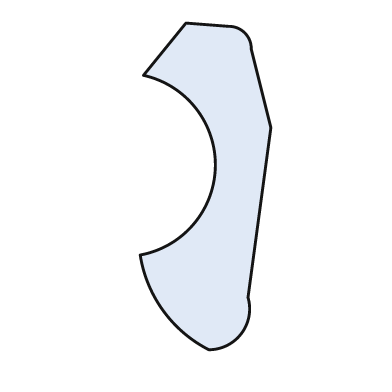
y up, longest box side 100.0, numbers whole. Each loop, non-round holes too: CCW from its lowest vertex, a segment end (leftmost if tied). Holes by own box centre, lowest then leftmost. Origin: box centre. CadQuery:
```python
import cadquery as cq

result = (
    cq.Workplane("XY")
    .moveTo(1.0, -50.0)
    .threePointArc((11.0, -45.0), (13.0, -34.0))
    .lineTo(20.0, 18.0)
    .lineTo(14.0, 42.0)
    .threePointArc((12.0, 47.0), (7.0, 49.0))
    .lineTo(-6.0, 50.0)
    .lineTo(-19.0, 34.0)
    .threePointArc((3.0, 6.0), (-20.0, -21.0))
    .threePointArc((-13.0, -38.0), (1.0, -50.0))
    .close()
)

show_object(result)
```